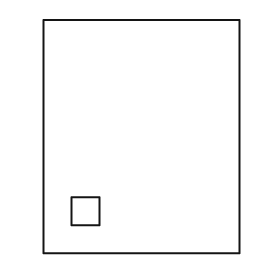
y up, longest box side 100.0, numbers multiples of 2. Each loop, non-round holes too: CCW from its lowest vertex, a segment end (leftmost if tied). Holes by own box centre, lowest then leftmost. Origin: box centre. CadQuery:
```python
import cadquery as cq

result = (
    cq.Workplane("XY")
    .moveTo(-42.0, -50.0)
    .lineTo(42.0, -50.0)
    .lineTo(42.0, 50.0)
    .lineTo(-42.0, 50.0)
    .close()
    .moveTo(-30.0, -38.0)
    .lineTo(-18.0, -38.0)
    .lineTo(-18.0, -26.0)
    .lineTo(-30.0, -26.0)
    .close()
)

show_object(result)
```